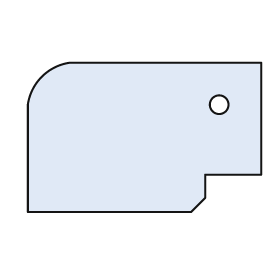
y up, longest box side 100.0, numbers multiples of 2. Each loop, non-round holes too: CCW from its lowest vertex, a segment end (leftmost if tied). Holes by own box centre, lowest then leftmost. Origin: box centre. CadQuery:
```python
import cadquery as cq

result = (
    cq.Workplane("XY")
    .moveTo(-50.0, -32.0)
    .lineTo(20.0, -32.0)
    .lineTo(26.0, -26.0)
    .lineTo(26.0, -16.0)
    .lineTo(50.0, -16.0)
    .lineTo(50.0, 32.0)
    .lineTo(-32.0, 32.0)
    .threePointArc((-44.0, 26.0), (-50.0, 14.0))
    .close()
    .moveTo(32.0, 14.0)
    .circle(4.0)
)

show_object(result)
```